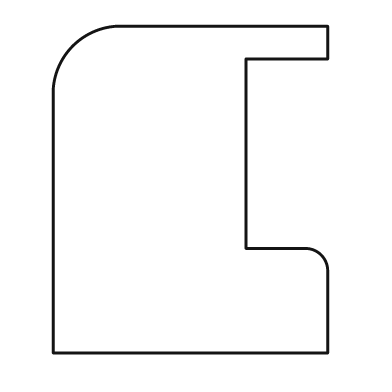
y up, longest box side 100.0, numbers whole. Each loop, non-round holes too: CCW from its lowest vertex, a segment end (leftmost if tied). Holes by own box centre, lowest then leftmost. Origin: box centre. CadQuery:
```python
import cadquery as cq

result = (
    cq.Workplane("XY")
    .moveTo(-42.0, -50.0)
    .lineTo(42.0, -50.0)
    .lineTo(42.0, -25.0)
    .threePointArc((40.0, -20.0), (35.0, -18.0))
    .lineTo(17.0, -18.0)
    .lineTo(17.0, 40.0)
    .lineTo(42.0, 40.0)
    .lineTo(42.0, 50.0)
    .lineTo(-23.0, 50.0)
    .threePointArc((-36.0, 44.0), (-42.0, 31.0))
    .close()
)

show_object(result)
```